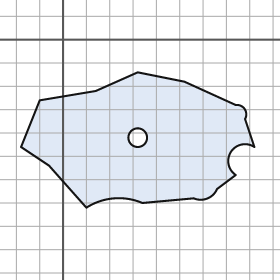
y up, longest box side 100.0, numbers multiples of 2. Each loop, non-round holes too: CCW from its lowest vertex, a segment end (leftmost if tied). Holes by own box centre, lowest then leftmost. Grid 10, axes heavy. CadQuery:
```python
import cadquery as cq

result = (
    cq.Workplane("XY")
    .moveTo(10.0, -72.0)
    .threePointArc((22.0, -68.0), (34.0, -70.0))
    .lineTo(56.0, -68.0)
    .threePointArc((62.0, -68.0), (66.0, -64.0))
    .lineTo(74.0, -58.0)
    .threePointArc((72.0, -48.0), (82.0, -46.0))
    .lineTo(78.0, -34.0)
    .threePointArc((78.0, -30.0), (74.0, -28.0))
    .lineTo(52.0, -18.0)
    .lineTo(32.0, -14.0)
    .lineTo(14.0, -22.0)
    .lineTo(-10.0, -26.0)
    .lineTo(-18.0, -46.0)
    .lineTo(-6.0, -54.0)
    .close()
    .moveTo(32.0, -42.0)
    .circle(4.0)
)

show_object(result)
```